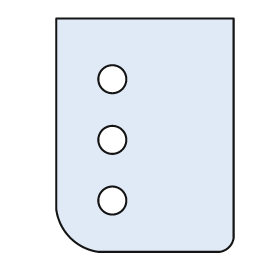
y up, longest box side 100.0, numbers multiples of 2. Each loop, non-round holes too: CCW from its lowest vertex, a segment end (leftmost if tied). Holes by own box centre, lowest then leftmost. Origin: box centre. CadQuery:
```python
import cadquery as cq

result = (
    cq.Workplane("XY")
    .moveTo(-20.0, -50.0)
    .lineTo(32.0, -50.0)
    .threePointArc((36.0, -48.0), (38.0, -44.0))
    .lineTo(38.0, 50.0)
    .lineTo(-38.0, 50.0)
    .lineTo(-38.0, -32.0)
    .threePointArc((-32.0, -44.0), (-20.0, -50.0))
    .close()
    .moveTo(-14.0, -28.0)
    .circle(6.0)
    .moveTo(-14.0, -2.0)
    .circle(6.0)
    .moveTo(-14.0, 24.0)
    .circle(6.0)
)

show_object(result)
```